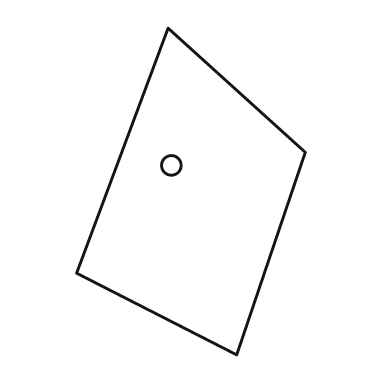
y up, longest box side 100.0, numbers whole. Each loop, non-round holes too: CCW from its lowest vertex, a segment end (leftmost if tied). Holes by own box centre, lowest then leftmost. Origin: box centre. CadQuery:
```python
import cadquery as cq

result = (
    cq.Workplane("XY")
    .moveTo(14.0, -50.0)
    .lineTo(35.0, 12.0)
    .lineTo(-7.0, 50.0)
    .lineTo(-35.0, -25.0)
    .close()
    .moveTo(-6.0, 8.0)
    .circle(3.0)
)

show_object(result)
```